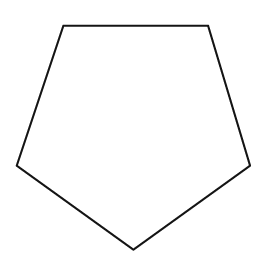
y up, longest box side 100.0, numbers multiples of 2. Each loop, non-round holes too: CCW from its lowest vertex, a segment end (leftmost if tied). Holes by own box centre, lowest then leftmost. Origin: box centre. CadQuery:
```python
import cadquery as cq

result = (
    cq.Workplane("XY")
    .moveTo(0.0, -48.0)
    .lineTo(50.0, -12.0)
    .lineTo(32.0, 48.0)
    .lineTo(-30.0, 48.0)
    .lineTo(-50.0, -12.0)
    .close()
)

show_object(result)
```